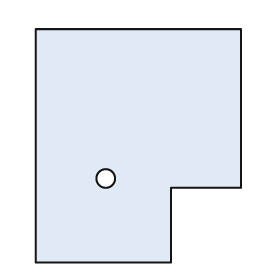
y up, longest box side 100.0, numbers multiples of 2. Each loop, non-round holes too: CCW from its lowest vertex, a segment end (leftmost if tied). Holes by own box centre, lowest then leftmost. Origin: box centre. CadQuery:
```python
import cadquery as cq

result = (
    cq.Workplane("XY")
    .moveTo(-44.0, -50.0)
    .lineTo(14.0, -50.0)
    .lineTo(14.0, -18.0)
    .lineTo(44.0, -18.0)
    .lineTo(44.0, 50.0)
    .lineTo(-44.0, 50.0)
    .close()
    .moveTo(-14.0, -14.0)
    .circle(4.0)
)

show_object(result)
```